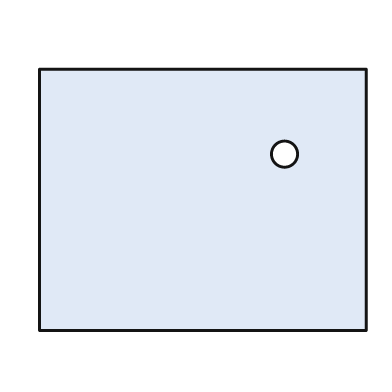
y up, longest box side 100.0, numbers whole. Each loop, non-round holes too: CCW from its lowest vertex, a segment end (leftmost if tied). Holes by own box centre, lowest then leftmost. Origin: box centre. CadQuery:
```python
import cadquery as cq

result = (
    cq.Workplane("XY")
    .moveTo(-50.0, -40.0)
    .lineTo(50.0, -40.0)
    .lineTo(50.0, 40.0)
    .lineTo(-50.0, 40.0)
    .close()
    .moveTo(25.0, 14.0)
    .circle(4.0)
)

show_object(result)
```